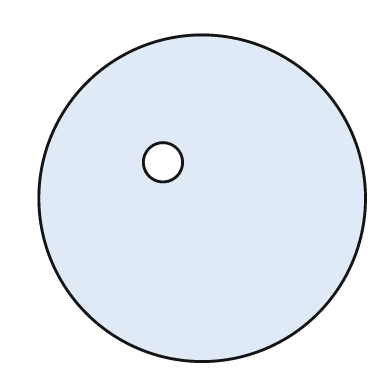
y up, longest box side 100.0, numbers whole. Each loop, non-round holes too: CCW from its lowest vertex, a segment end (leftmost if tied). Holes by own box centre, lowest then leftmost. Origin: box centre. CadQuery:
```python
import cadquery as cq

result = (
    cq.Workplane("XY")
    .moveTo(0.0, 0.0)
    .circle(50.0)
    .moveTo(-12.0, 11.0)
    .circle(6.0)
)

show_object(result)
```